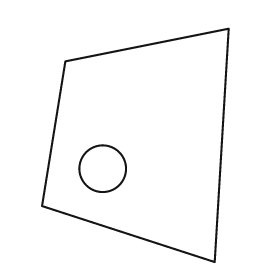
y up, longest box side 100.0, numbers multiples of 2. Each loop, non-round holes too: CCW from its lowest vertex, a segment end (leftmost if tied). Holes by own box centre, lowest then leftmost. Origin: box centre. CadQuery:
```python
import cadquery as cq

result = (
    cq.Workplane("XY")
    .moveTo(34.0, -50.0)
    .lineTo(40.0, 50.0)
    .lineTo(-30.0, 36.0)
    .lineTo(-40.0, -26.0)
    .close()
    .moveTo(-14.0, -10.0)
    .circle(10.0)
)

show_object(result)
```